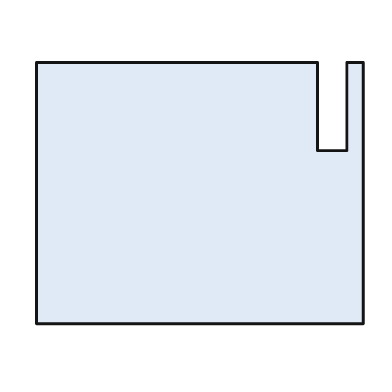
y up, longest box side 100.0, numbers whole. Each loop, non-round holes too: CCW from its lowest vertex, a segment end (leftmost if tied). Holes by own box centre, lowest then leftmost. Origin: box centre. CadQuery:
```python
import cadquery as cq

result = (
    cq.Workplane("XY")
    .moveTo(-50.0, -40.0)
    .lineTo(50.0, -40.0)
    .lineTo(50.0, 40.0)
    .lineTo(45.0, 40.0)
    .lineTo(45.0, 13.0)
    .lineTo(36.0, 13.0)
    .lineTo(36.0, 40.0)
    .lineTo(-50.0, 40.0)
    .close()
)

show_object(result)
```